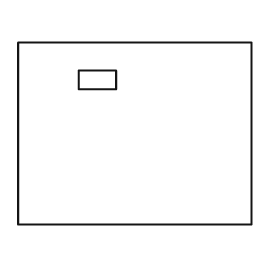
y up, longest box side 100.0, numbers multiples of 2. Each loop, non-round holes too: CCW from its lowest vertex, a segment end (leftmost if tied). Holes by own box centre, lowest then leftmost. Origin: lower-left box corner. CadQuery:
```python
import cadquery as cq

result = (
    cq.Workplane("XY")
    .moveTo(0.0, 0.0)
    .lineTo(100.0, 0.0)
    .lineTo(100.0, 78.0)
    .lineTo(0.0, 78.0)
    .close()
    .moveTo(26.0, 58.0)
    .lineTo(42.0, 58.0)
    .lineTo(42.0, 66.0)
    .lineTo(26.0, 66.0)
    .close()
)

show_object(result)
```